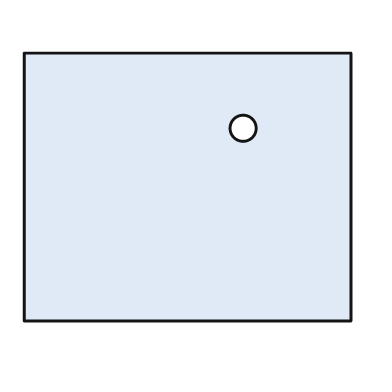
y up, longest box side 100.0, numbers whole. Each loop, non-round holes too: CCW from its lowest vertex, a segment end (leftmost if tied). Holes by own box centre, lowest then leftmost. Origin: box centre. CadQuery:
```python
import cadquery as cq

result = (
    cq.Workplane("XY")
    .moveTo(-50.0, -41.0)
    .lineTo(50.0, -41.0)
    .lineTo(50.0, 41.0)
    .lineTo(-50.0, 41.0)
    .close()
    .moveTo(17.0, 18.0)
    .circle(4.0)
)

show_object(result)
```